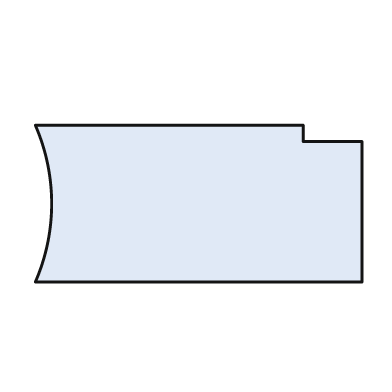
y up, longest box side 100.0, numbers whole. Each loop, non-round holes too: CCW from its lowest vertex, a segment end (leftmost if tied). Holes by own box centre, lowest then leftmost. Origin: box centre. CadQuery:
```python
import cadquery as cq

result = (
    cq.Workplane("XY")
    .moveTo(-50.0, -24.0)
    .lineTo(50.0, -24.0)
    .lineTo(50.0, 19.0)
    .lineTo(32.0, 19.0)
    .lineTo(32.0, 24.0)
    .lineTo(-50.0, 24.0)
    .threePointArc((-45.0, 0.0), (-50.0, -24.0))
    .close()
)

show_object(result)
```